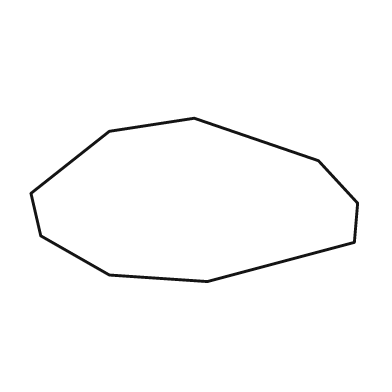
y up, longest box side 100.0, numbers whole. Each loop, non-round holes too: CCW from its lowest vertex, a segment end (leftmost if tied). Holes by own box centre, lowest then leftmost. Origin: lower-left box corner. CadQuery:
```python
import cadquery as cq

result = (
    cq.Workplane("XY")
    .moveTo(54.0, 0.0)
    .lineTo(99.0, 12.0)
    .lineTo(100.0, 24.0)
    .lineTo(88.0, 37.0)
    .lineTo(50.0, 50.0)
    .lineTo(24.0, 46.0)
    .lineTo(0.0, 27.0)
    .lineTo(3.0, 14.0)
    .lineTo(24.0, 2.0)
    .close()
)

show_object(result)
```